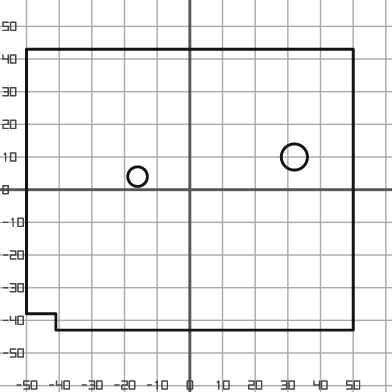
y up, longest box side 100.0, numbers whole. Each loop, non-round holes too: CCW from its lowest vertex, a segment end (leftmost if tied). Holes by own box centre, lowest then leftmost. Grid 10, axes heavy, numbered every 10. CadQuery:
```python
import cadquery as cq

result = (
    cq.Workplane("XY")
    .moveTo(-41.0, -43.0)
    .lineTo(50.0, -43.0)
    .lineTo(50.0, 43.0)
    .lineTo(-50.0, 43.0)
    .lineTo(-50.0, -38.0)
    .lineTo(-41.0, -38.0)
    .close()
    .moveTo(-16.0, 4.0)
    .circle(3.0)
    .moveTo(32.0, 10.0)
    .circle(4.0)
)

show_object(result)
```